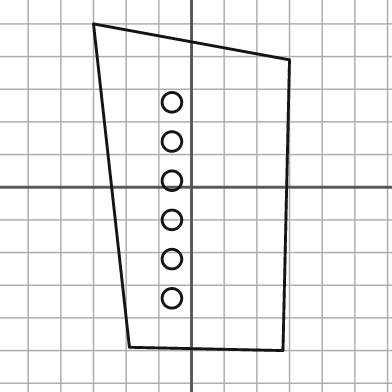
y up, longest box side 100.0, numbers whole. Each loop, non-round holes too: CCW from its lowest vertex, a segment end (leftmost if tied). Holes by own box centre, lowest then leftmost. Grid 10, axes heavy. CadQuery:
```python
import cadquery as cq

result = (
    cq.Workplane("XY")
    .moveTo(28.0, -50.0)
    .lineTo(30.0, 39.0)
    .lineTo(-30.0, 50.0)
    .lineTo(-19.0, -49.0)
    .close()
    .moveTo(-6.0, -34.0)
    .circle(3.0)
    .moveTo(-6.0, -22.0)
    .circle(3.0)
    .moveTo(-6.0, -10.0)
    .circle(3.0)
    .moveTo(-6.0, 2.0)
    .circle(3.0)
    .moveTo(-6.0, 14.0)
    .circle(3.0)
    .moveTo(-6.0, 26.0)
    .circle(3.0)
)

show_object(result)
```